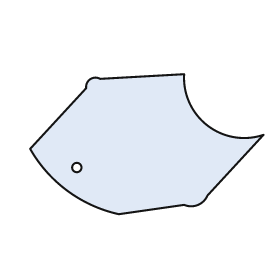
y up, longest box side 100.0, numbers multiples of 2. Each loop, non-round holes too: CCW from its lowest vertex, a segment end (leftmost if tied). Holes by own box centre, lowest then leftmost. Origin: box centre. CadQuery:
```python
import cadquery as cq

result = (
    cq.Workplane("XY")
    .moveTo(-12.0, -30.0)
    .lineTo(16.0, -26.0)
    .threePointArc((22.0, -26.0), (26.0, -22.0))
    .lineTo(50.0, 4.0)
    .threePointArc((26.0, 8.0), (16.0, 30.0))
    .lineTo(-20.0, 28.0)
    .threePointArc((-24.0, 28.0), (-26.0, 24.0))
    .lineTo(-50.0, -2.0)
    .threePointArc((-34.0, -20.0), (-12.0, -30.0))
    .close()
    .moveTo(-30.0, -10.0)
    .circle(2.0)
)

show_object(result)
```